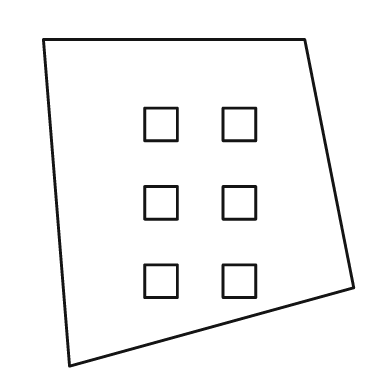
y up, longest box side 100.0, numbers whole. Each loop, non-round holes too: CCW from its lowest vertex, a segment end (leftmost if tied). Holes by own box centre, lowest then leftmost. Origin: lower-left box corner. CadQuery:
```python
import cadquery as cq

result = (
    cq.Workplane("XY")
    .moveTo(8.0, 0.0)
    .lineTo(95.0, 24.0)
    .lineTo(80.0, 100.0)
    .lineTo(0.0, 100.0)
    .close()
    .moveTo(31.0, 21.0)
    .lineTo(41.0, 21.0)
    .lineTo(41.0, 31.0)
    .lineTo(31.0, 31.0)
    .close()
    .moveTo(55.0, 21.0)
    .lineTo(65.0, 21.0)
    .lineTo(65.0, 31.0)
    .lineTo(55.0, 31.0)
    .close()
    .moveTo(31.0, 45.0)
    .lineTo(41.0, 45.0)
    .lineTo(41.0, 55.0)
    .lineTo(31.0, 55.0)
    .close()
    .moveTo(55.0, 45.0)
    .lineTo(65.0, 45.0)
    .lineTo(65.0, 55.0)
    .lineTo(55.0, 55.0)
    .close()
    .moveTo(31.0, 69.0)
    .lineTo(41.0, 69.0)
    .lineTo(41.0, 79.0)
    .lineTo(31.0, 79.0)
    .close()
    .moveTo(55.0, 69.0)
    .lineTo(65.0, 69.0)
    .lineTo(65.0, 79.0)
    .lineTo(55.0, 79.0)
    .close()
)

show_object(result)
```